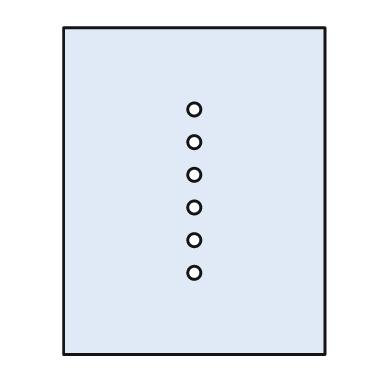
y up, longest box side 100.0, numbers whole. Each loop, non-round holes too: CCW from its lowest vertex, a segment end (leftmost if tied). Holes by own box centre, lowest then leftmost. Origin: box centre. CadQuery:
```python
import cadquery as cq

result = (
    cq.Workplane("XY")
    .moveTo(-40.0, -50.0)
    .lineTo(40.0, -50.0)
    .lineTo(40.0, 50.0)
    .lineTo(-40.0, 50.0)
    .close()
    .moveTo(0.0, -25.0)
    .circle(2.0)
    .moveTo(0.0, -15.0)
    .circle(2.0)
    .moveTo(0.0, -5.0)
    .circle(2.0)
    .moveTo(0.0, 5.0)
    .circle(2.0)
    .moveTo(0.0, 15.0)
    .circle(2.0)
    .moveTo(0.0, 25.0)
    .circle(2.0)
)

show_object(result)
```